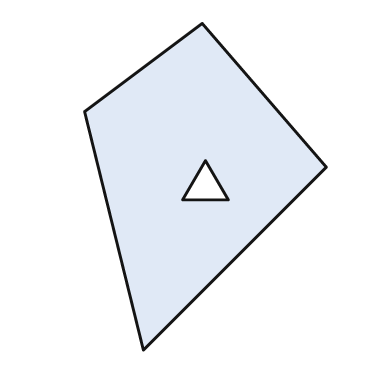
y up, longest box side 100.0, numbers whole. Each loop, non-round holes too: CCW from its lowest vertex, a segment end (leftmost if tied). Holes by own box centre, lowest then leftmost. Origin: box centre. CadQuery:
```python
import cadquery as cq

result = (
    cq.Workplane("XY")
    .moveTo(-19.0, -50.0)
    .lineTo(37.0, 6.0)
    .lineTo(-1.0, 50.0)
    .lineTo(-37.0, 23.0)
    .close()
    .moveTo(-7.0, -4.0)
    .lineTo(7.0, -4.0)
    .lineTo(0.0, 8.0)
    .close()
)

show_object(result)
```